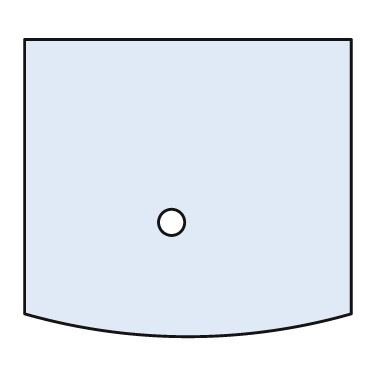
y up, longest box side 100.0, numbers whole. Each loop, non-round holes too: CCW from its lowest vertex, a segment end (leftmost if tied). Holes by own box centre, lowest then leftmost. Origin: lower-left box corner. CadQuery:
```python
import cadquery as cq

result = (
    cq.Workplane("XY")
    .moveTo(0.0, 7.0)
    .threePointArc((50.0, 0.0), (100.0, 7.0))
    .lineTo(100.0, 91.0)
    .lineTo(0.0, 91.0)
    .close()
    .moveTo(45.0, 35.0)
    .circle(4.0)
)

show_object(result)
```